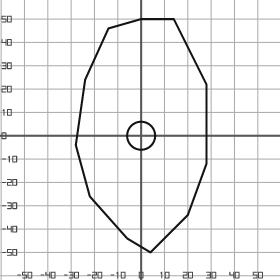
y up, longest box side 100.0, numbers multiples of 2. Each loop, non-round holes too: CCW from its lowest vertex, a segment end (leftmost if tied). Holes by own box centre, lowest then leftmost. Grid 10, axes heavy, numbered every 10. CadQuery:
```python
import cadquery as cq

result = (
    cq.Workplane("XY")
    .moveTo(4.0, -50.0)
    .lineTo(20.0, -34.0)
    .lineTo(28.0, -12.0)
    .lineTo(28.0, 22.0)
    .lineTo(14.0, 50.0)
    .lineTo(0.0, 50.0)
    .lineTo(-14.0, 46.0)
    .lineTo(-24.0, 24.0)
    .lineTo(-28.0, -4.0)
    .lineTo(-22.0, -26.0)
    .lineTo(-6.0, -44.0)
    .close()
    .moveTo(0.0, 0.0)
    .circle(6.0)
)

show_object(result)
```